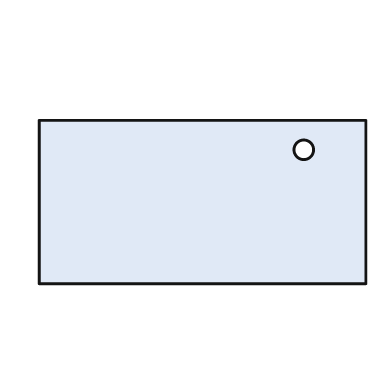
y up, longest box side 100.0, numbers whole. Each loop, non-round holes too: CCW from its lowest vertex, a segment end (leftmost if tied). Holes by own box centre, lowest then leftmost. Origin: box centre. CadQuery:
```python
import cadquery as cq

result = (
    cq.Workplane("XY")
    .moveTo(-50.0, -25.0)
    .lineTo(50.0, -25.0)
    .lineTo(50.0, 25.0)
    .lineTo(-50.0, 25.0)
    .close()
    .moveTo(31.0, 16.0)
    .circle(3.0)
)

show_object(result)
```